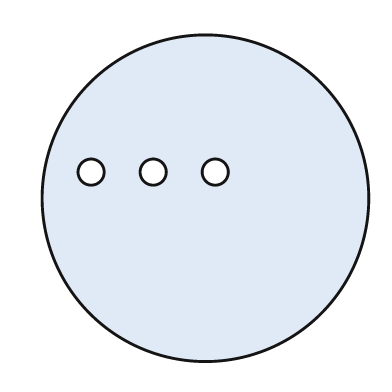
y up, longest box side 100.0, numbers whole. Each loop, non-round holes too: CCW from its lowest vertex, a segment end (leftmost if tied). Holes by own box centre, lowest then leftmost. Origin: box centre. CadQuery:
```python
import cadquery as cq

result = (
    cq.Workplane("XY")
    .moveTo(0.0, 0.0)
    .circle(50.0)
    .moveTo(-35.0, 8.0)
    .circle(4.0)
    .moveTo(-16.0, 8.0)
    .circle(4.0)
    .moveTo(3.0, 8.0)
    .circle(4.0)
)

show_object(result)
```